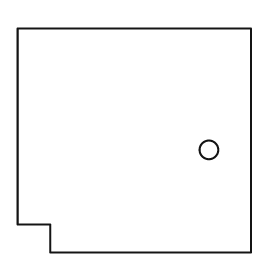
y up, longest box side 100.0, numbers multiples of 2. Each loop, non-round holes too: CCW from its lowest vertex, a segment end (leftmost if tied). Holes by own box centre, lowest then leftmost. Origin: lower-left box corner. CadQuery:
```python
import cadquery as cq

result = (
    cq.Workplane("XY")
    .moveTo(14.0, 0.0)
    .lineTo(100.0, 0.0)
    .lineTo(100.0, 96.0)
    .lineTo(0.0, 96.0)
    .lineTo(0.0, 12.0)
    .lineTo(14.0, 12.0)
    .close()
    .moveTo(82.0, 44.0)
    .circle(4.0)
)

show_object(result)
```